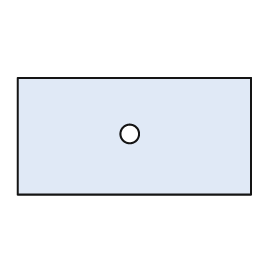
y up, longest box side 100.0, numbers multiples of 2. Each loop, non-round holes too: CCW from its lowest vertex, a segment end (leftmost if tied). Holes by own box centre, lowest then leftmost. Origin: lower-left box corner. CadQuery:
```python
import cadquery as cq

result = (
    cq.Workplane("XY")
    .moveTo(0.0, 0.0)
    .lineTo(100.0, 0.0)
    .lineTo(100.0, 50.0)
    .lineTo(0.0, 50.0)
    .close()
    .moveTo(48.0, 26.0)
    .circle(4.0)
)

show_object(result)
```